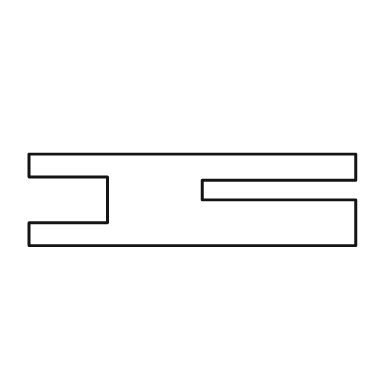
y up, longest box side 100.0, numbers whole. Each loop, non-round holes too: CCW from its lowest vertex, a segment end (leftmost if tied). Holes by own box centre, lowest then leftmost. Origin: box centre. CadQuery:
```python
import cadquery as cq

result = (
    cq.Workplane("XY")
    .moveTo(-50.0, -14.0)
    .lineTo(50.0, -14.0)
    .lineTo(50.0, 0.0)
    .lineTo(3.0, 0.0)
    .lineTo(3.0, 6.0)
    .lineTo(50.0, 6.0)
    .lineTo(50.0, 14.0)
    .lineTo(-50.0, 14.0)
    .lineTo(-50.0, 7.0)
    .lineTo(-26.0, 7.0)
    .lineTo(-26.0, -7.0)
    .lineTo(-50.0, -7.0)
    .close()
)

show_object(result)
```